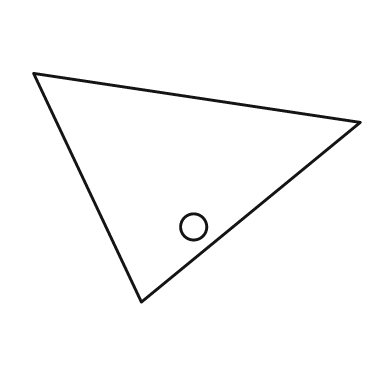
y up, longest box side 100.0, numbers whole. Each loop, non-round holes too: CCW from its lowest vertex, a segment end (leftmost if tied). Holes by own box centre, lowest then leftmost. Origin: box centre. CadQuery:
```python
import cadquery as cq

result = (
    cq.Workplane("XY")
    .moveTo(-17.0, -35.0)
    .lineTo(50.0, 20.0)
    .lineTo(-50.0, 35.0)
    .close()
    .moveTo(-1.0, -12.0)
    .circle(4.0)
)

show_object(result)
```